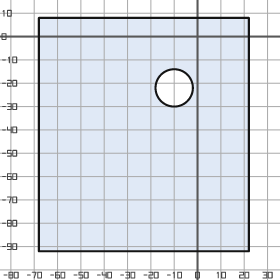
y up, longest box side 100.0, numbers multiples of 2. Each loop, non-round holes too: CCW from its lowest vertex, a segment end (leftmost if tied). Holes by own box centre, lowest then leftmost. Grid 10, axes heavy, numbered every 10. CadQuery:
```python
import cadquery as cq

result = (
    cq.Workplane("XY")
    .moveTo(-68.0, -92.0)
    .lineTo(22.0, -92.0)
    .lineTo(22.0, 8.0)
    .lineTo(-68.0, 8.0)
    .close()
    .moveTo(-10.0, -22.0)
    .circle(8.0)
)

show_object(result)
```